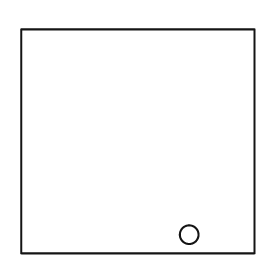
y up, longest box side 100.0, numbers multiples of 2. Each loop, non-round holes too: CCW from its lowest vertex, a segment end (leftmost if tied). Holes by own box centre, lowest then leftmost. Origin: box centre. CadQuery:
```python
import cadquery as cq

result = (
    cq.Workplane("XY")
    .moveTo(-50.0, -48.0)
    .lineTo(50.0, -48.0)
    .lineTo(50.0, 48.0)
    .lineTo(-50.0, 48.0)
    .close()
    .moveTo(22.0, -40.0)
    .circle(4.0)
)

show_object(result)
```